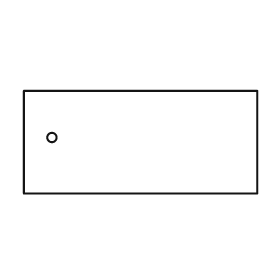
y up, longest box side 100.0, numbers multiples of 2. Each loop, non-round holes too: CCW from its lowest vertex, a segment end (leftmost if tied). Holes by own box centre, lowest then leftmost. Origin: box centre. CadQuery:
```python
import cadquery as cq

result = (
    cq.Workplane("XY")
    .moveTo(-50.0, -22.0)
    .lineTo(50.0, -22.0)
    .lineTo(50.0, 22.0)
    .lineTo(-50.0, 22.0)
    .close()
    .moveTo(-38.0, 2.0)
    .circle(2.0)
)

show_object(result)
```